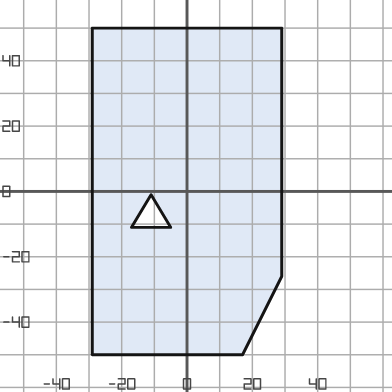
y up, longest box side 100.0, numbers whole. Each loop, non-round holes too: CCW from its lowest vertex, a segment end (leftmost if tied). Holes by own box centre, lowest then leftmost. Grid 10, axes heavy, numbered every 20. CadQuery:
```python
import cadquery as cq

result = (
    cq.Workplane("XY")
    .moveTo(-29.0, -50.0)
    .lineTo(17.0, -50.0)
    .lineTo(29.0, -26.0)
    .lineTo(29.0, 50.0)
    .lineTo(-29.0, 50.0)
    .close()
    .moveTo(-17.0, -11.0)
    .lineTo(-5.0, -11.0)
    .lineTo(-11.0, -1.0)
    .close()
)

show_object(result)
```